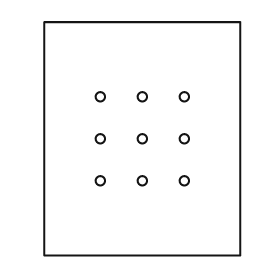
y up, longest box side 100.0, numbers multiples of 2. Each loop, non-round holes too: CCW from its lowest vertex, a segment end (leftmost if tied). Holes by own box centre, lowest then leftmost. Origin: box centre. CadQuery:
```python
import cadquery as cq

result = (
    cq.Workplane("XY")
    .moveTo(-42.0, -50.0)
    .lineTo(42.0, -50.0)
    .lineTo(42.0, 50.0)
    .lineTo(-42.0, 50.0)
    .close()
    .moveTo(-18.0, -18.0)
    .circle(2.0)
    .moveTo(0.0, -18.0)
    .circle(2.0)
    .moveTo(18.0, -18.0)
    .circle(2.0)
    .moveTo(-18.0, 0.0)
    .circle(2.0)
    .moveTo(0.0, 0.0)
    .circle(2.0)
    .moveTo(18.0, 0.0)
    .circle(2.0)
    .moveTo(-18.0, 18.0)
    .circle(2.0)
    .moveTo(0.0, 18.0)
    .circle(2.0)
    .moveTo(18.0, 18.0)
    .circle(2.0)
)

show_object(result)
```